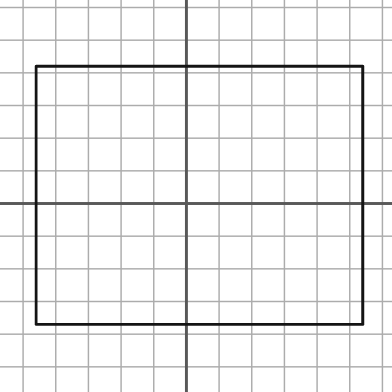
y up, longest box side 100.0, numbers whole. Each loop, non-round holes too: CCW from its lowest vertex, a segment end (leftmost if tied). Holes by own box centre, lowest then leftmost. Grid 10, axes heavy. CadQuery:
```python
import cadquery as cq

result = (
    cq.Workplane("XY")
    .moveTo(-46.0, -37.0)
    .lineTo(54.0, -37.0)
    .lineTo(54.0, 42.0)
    .lineTo(-46.0, 42.0)
    .close()
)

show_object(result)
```